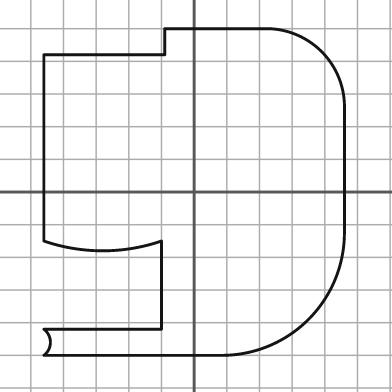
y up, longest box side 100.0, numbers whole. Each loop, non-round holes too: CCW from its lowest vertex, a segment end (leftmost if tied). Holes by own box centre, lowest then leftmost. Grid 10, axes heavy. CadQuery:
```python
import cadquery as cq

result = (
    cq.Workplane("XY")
    .moveTo(-46.0, -50.0)
    .lineTo(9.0, -50.0)
    .threePointArc((35.0, -39.0), (46.0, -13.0))
    .lineTo(46.0, 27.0)
    .threePointArc((39.0, 43.0), (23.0, 50.0))
    .lineTo(-9.0, 50.0)
    .lineTo(-9.0, 42.0)
    .lineTo(-46.0, 42.0)
    .lineTo(-46.0, -15.0)
    .threePointArc((-28.0, -18.0), (-10.0, -15.0))
    .lineTo(-10.0, -42.0)
    .lineTo(-46.0, -42.0)
    .threePointArc((-44.0, -46.0), (-46.0, -50.0))
    .close()
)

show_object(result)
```